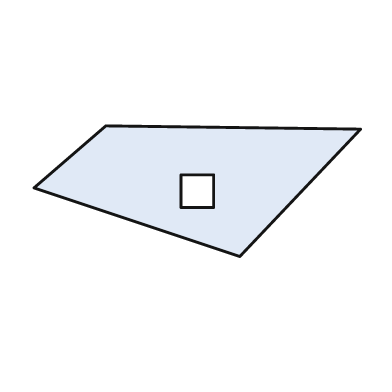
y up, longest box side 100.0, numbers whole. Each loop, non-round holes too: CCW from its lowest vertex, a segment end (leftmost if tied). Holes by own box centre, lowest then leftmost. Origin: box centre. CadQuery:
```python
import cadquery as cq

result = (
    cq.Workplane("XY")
    .moveTo(13.0, -20.0)
    .lineTo(50.0, 19.0)
    .lineTo(-28.0, 20.0)
    .lineTo(-50.0, 1.0)
    .close()
    .moveTo(-5.0, -5.0)
    .lineTo(5.0, -5.0)
    .lineTo(5.0, 5.0)
    .lineTo(-5.0, 5.0)
    .close()
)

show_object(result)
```